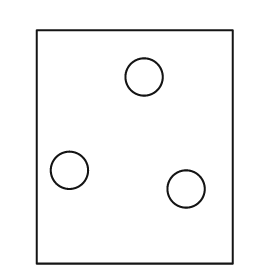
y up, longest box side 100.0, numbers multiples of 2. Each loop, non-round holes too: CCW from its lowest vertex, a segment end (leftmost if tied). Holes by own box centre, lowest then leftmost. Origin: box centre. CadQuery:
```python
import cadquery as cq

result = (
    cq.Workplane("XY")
    .moveTo(-42.0, -50.0)
    .lineTo(42.0, -50.0)
    .lineTo(42.0, 50.0)
    .lineTo(-42.0, 50.0)
    .close()
    .moveTo(22.0, -18.0)
    .circle(8.0)
    .moveTo(-28.0, -10.0)
    .circle(8.0)
    .moveTo(4.0, 30.0)
    .circle(8.0)
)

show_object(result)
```